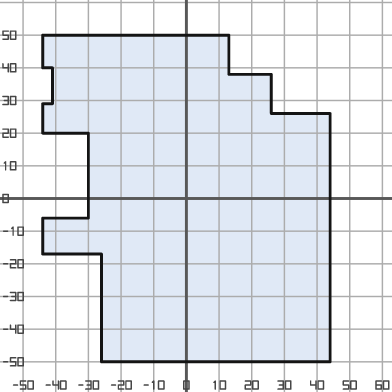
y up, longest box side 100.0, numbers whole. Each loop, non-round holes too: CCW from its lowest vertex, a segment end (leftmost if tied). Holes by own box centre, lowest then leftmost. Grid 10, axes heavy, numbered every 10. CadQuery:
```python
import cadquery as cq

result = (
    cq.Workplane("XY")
    .moveTo(-26.0, -50.0)
    .lineTo(44.0, -50.0)
    .lineTo(44.0, 26.0)
    .lineTo(26.0, 26.0)
    .lineTo(26.0, 38.0)
    .lineTo(13.0, 38.0)
    .lineTo(13.0, 50.0)
    .lineTo(-44.0, 50.0)
    .lineTo(-44.0, 40.0)
    .lineTo(-41.0, 40.0)
    .lineTo(-41.0, 29.0)
    .lineTo(-44.0, 29.0)
    .lineTo(-44.0, 20.0)
    .lineTo(-30.0, 20.0)
    .lineTo(-30.0, -6.0)
    .lineTo(-44.0, -6.0)
    .lineTo(-44.0, -17.0)
    .lineTo(-26.0, -17.0)
    .close()
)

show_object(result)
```